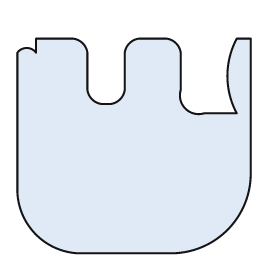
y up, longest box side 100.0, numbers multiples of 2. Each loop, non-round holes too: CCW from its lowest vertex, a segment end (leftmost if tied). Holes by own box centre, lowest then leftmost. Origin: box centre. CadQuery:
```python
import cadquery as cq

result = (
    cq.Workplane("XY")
    .moveTo(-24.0, -46.0)
    .lineTo(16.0, -46.0)
    .threePointArc((40.0, -36.0), (50.0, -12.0))
    .lineTo(50.0, 46.0)
    .lineTo(44.0, 46.0)
    .threePointArc((40.0, 30.0), (44.0, 14.0))
    .lineTo(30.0, 14.0)
    .threePointArc((22.0, 16.0), (20.0, 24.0))
    .lineTo(20.0, 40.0)
    .threePointArc((18.0, 44.0), (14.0, 46.0))
    .lineTo(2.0, 46.0)
    .threePointArc((-2.0, 44.0), (-4.0, 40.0))
    .lineTo(-4.0, 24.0)
    .threePointArc((-6.0, 20.0), (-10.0, 18.0))
    .lineTo(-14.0, 18.0)
    .threePointArc((-18.0, 20.0), (-20.0, 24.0))
    .lineTo(-20.0, 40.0)
    .threePointArc((-22.0, 44.0), (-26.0, 46.0))
    .lineTo(-42.0, 46.0)
    .lineTo(-42.0, 40.0)
    .threePointArc((-46.0, 42.0), (-50.0, 40.0))
    .lineTo(-50.0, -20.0)
    .threePointArc((-42.0, -38.0), (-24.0, -46.0))
    .close()
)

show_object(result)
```